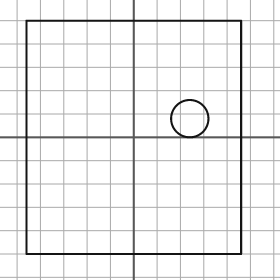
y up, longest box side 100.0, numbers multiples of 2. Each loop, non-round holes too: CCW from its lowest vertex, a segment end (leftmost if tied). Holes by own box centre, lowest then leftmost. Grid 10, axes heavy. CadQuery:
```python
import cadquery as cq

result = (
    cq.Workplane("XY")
    .moveTo(-46.0, -50.0)
    .lineTo(46.0, -50.0)
    .lineTo(46.0, 50.0)
    .lineTo(-46.0, 50.0)
    .close()
    .moveTo(24.0, 8.0)
    .circle(8.0)
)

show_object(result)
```